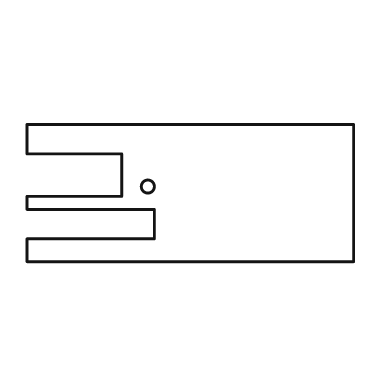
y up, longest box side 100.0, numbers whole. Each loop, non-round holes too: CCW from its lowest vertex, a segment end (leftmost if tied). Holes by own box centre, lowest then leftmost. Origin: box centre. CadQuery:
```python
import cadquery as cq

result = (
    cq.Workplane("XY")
    .moveTo(-50.0, -21.0)
    .lineTo(50.0, -21.0)
    .lineTo(50.0, 21.0)
    .lineTo(-50.0, 21.0)
    .lineTo(-50.0, 12.0)
    .lineTo(-21.0, 12.0)
    .lineTo(-21.0, -1.0)
    .lineTo(-50.0, -1.0)
    .lineTo(-50.0, -5.0)
    .lineTo(-11.0, -5.0)
    .lineTo(-11.0, -14.0)
    .lineTo(-50.0, -14.0)
    .close()
    .moveTo(-13.0, 2.0)
    .circle(2.0)
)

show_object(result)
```